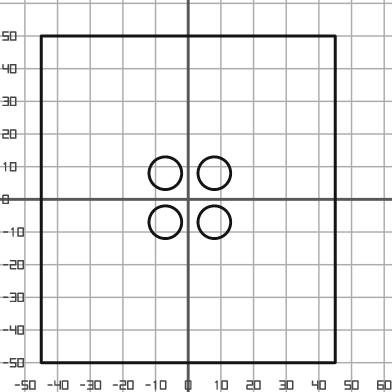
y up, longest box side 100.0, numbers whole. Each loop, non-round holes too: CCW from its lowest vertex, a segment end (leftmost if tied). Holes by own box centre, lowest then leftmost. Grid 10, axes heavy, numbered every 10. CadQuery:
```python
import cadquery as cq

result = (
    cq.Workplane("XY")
    .moveTo(-45.0, -50.0)
    .lineTo(45.0, -50.0)
    .lineTo(45.0, 50.0)
    .lineTo(-45.0, 50.0)
    .close()
    .moveTo(-7.0, -7.0)
    .circle(5.0)
    .moveTo(8.0, -7.0)
    .circle(5.0)
    .moveTo(-7.0, 8.0)
    .circle(5.0)
    .moveTo(8.0, 8.0)
    .circle(5.0)
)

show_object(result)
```